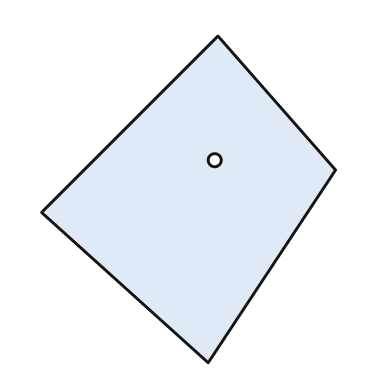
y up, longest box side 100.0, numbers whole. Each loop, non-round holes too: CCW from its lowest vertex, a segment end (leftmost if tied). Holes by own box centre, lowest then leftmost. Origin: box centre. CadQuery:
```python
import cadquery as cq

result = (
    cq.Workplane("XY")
    .moveTo(6.0, -50.0)
    .lineTo(45.0, 9.0)
    .lineTo(9.0, 50.0)
    .lineTo(-45.0, -4.0)
    .close()
    .moveTo(8.0, 12.0)
    .circle(2.0)
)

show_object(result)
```